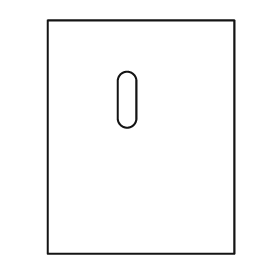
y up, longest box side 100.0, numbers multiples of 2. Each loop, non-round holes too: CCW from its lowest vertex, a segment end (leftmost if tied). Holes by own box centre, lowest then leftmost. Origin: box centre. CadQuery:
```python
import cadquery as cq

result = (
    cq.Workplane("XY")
    .moveTo(-40.0, -50.0)
    .lineTo(40.0, -50.0)
    .lineTo(40.0, 50.0)
    .lineTo(-40.0, 50.0)
    .close()
    .moveTo(-10.0, 8.0)
    .threePointArc((-6.0, 4.0), (-2.0, 8.0))
    .lineTo(-2.0, 24.0)
    .threePointArc((-6.0, 28.0), (-10.0, 24.0))
    .close()
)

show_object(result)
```